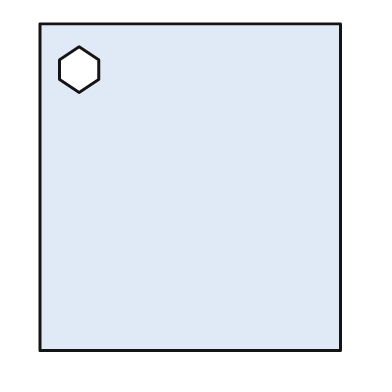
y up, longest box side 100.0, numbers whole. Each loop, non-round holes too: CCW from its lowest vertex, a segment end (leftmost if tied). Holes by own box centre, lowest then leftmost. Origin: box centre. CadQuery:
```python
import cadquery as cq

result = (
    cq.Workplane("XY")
    .moveTo(-46.0, -50.0)
    .lineTo(46.0, -50.0)
    .lineTo(46.0, 50.0)
    .lineTo(-46.0, 50.0)
    .close()
    .moveTo(-34.0, 29.0)
    .lineTo(-28.0, 33.0)
    .lineTo(-28.0, 39.0)
    .lineTo(-34.0, 43.0)
    .lineTo(-40.0, 39.0)
    .lineTo(-40.0, 33.0)
    .close()
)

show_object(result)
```